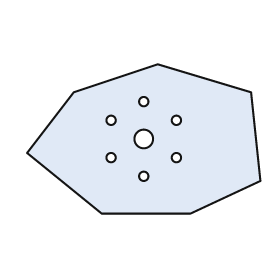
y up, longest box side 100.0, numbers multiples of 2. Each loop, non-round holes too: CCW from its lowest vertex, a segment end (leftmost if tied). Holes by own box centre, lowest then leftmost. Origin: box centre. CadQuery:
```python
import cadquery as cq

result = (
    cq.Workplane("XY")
    .moveTo(-18.0, -32.0)
    .lineTo(20.0, -32.0)
    .lineTo(50.0, -18.0)
    .lineTo(46.0, 20.0)
    .lineTo(6.0, 32.0)
    .lineTo(-30.0, 20.0)
    .lineTo(-50.0, -6.0)
    .close()
    .moveTo(0.0, -16.0)
    .circle(2.0)
    .moveTo(-14.0, -8.0)
    .circle(2.0)
    .moveTo(14.0, -8.0)
    .circle(2.0)
    .moveTo(0.0, 0.0)
    .circle(4.0)
    .moveTo(-14.0, 8.0)
    .circle(2.0)
    .moveTo(14.0, 8.0)
    .circle(2.0)
    .moveTo(0.0, 16.0)
    .circle(2.0)
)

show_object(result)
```